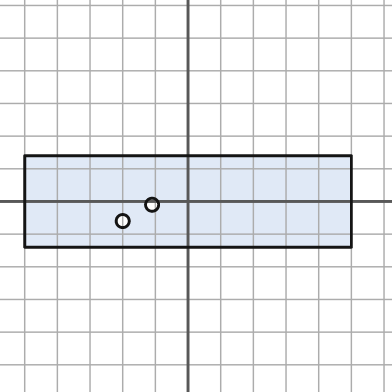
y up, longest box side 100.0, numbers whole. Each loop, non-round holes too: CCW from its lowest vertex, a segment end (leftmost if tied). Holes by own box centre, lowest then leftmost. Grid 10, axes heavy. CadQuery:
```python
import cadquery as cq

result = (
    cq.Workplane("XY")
    .moveTo(-50.0, -14.0)
    .lineTo(50.0, -14.0)
    .lineTo(50.0, 14.0)
    .lineTo(-50.0, 14.0)
    .close()
    .moveTo(-20.0, -6.0)
    .circle(2.0)
    .moveTo(-11.0, -1.0)
    .circle(2.0)
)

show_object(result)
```